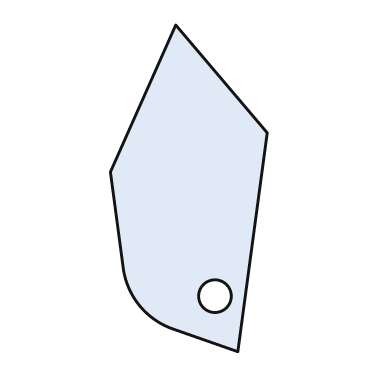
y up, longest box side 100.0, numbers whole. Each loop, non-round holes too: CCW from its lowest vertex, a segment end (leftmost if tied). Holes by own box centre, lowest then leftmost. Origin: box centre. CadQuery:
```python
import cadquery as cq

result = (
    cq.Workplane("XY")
    .moveTo(15.0, -50.0)
    .lineTo(24.0, 17.0)
    .lineTo(-4.0, 50.0)
    .lineTo(-24.0, 5.0)
    .lineTo(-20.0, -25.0)
    .threePointArc((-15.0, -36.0), (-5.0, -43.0))
    .close()
    .moveTo(8.0, -33.0)
    .circle(5.0)
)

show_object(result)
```